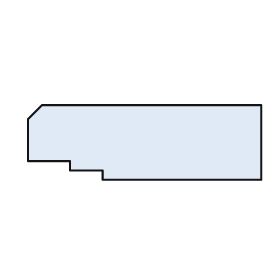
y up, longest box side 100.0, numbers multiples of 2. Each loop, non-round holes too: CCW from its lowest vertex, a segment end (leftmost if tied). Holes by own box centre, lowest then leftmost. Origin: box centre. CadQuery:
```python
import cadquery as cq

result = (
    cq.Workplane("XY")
    .moveTo(-18.0, -16.0)
    .lineTo(50.0, -16.0)
    .lineTo(50.0, 16.0)
    .lineTo(-44.0, 16.0)
    .lineTo(-50.0, 10.0)
    .lineTo(-50.0, -8.0)
    .lineTo(-32.0, -8.0)
    .lineTo(-32.0, -12.0)
    .lineTo(-18.0, -12.0)
    .close()
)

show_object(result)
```